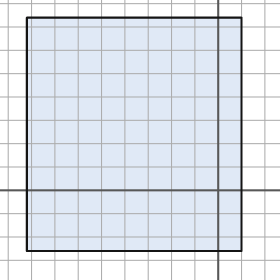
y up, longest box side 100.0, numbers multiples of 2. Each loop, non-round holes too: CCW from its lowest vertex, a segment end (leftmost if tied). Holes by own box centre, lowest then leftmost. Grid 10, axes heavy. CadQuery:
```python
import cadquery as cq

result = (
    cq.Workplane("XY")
    .moveTo(-82.0, -26.0)
    .lineTo(10.0, -26.0)
    .lineTo(10.0, 74.0)
    .lineTo(-82.0, 74.0)
    .close()
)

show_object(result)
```